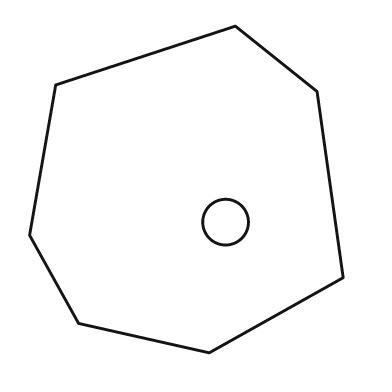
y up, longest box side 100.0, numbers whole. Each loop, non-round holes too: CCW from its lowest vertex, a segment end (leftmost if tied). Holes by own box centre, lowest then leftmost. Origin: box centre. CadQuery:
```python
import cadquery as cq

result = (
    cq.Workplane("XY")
    .moveTo(7.0, -50.0)
    .lineTo(48.0, -27.0)
    .lineTo(40.0, 30.0)
    .lineTo(15.0, 50.0)
    .lineTo(-40.0, 32.0)
    .lineTo(-48.0, -14.0)
    .lineTo(-33.0, -41.0)
    .close()
    .moveTo(12.0, -10.0)
    .circle(7.0)
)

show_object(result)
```